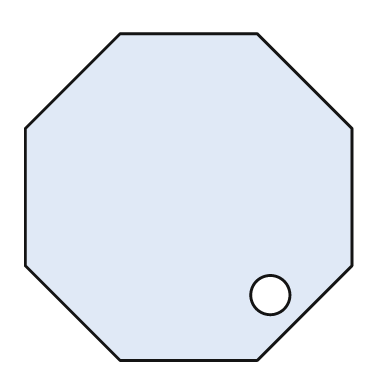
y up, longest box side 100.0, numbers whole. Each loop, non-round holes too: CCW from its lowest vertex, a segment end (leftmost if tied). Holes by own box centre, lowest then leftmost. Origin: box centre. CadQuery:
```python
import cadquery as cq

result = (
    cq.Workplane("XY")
    .moveTo(-21.0, -50.0)
    .lineTo(21.0, -50.0)
    .lineTo(50.0, -21.0)
    .lineTo(50.0, 21.0)
    .lineTo(21.0, 50.0)
    .lineTo(-21.0, 50.0)
    .lineTo(-50.0, 21.0)
    .lineTo(-50.0, -21.0)
    .close()
    .moveTo(25.0, -30.0)
    .circle(6.0)
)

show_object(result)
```